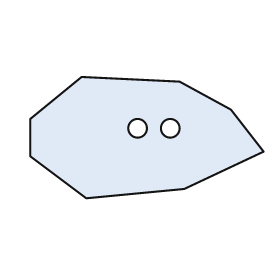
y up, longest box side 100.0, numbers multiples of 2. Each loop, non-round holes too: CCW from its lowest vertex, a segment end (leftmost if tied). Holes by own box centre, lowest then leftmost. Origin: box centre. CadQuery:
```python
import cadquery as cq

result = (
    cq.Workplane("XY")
    .moveTo(-26.0, -26.0)
    .lineTo(16.0, -22.0)
    .lineTo(50.0, -6.0)
    .lineTo(36.0, 12.0)
    .lineTo(14.0, 24.0)
    .lineTo(-28.0, 26.0)
    .lineTo(-50.0, 8.0)
    .lineTo(-50.0, -8.0)
    .close()
    .moveTo(-4.0, 4.0)
    .circle(4.0)
    .moveTo(10.0, 4.0)
    .circle(4.0)
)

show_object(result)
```